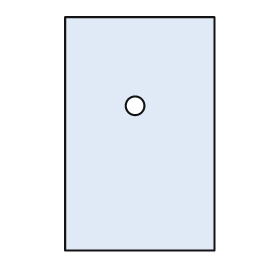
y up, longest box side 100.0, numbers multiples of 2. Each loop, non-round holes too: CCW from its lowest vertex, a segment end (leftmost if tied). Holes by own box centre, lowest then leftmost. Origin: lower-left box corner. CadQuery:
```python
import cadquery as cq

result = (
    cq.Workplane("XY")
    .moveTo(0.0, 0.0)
    .lineTo(64.0, 0.0)
    .lineTo(64.0, 100.0)
    .lineTo(0.0, 100.0)
    .close()
    .moveTo(30.0, 62.0)
    .circle(4.0)
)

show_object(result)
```